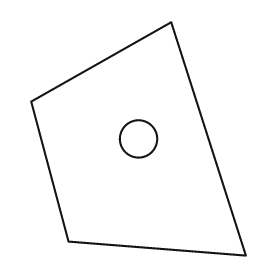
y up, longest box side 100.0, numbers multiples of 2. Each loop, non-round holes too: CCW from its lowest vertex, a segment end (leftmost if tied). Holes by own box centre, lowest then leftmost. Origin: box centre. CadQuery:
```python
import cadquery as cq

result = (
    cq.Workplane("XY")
    .moveTo(46.0, -50.0)
    .lineTo(14.0, 50.0)
    .lineTo(-46.0, 16.0)
    .lineTo(-30.0, -44.0)
    .close()
    .moveTo(0.0, 0.0)
    .circle(8.0)
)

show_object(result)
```